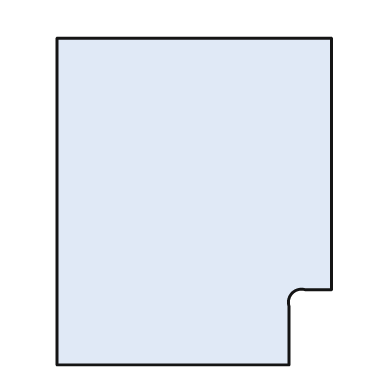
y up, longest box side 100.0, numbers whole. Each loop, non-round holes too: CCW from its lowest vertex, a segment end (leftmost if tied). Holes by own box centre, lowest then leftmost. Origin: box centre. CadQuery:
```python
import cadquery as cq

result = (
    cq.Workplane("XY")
    .moveTo(-42.0, -50.0)
    .lineTo(29.0, -50.0)
    .lineTo(29.0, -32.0)
    .threePointArc((30.0, -28.0), (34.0, -27.0))
    .lineTo(42.0, -27.0)
    .lineTo(42.0, 50.0)
    .lineTo(-42.0, 50.0)
    .close()
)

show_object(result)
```